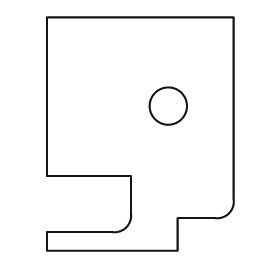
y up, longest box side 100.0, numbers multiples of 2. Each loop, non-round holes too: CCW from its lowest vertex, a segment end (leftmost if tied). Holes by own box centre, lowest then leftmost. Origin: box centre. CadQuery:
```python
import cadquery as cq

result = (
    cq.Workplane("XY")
    .moveTo(-40.0, -50.0)
    .lineTo(16.0, -50.0)
    .lineTo(16.0, -36.0)
    .lineTo(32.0, -36.0)
    .threePointArc((38.0, -34.0), (40.0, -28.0))
    .lineTo(40.0, 50.0)
    .lineTo(-40.0, 50.0)
    .lineTo(-40.0, -18.0)
    .lineTo(-4.0, -18.0)
    .lineTo(-4.0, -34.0)
    .threePointArc((-6.0, -40.0), (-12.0, -42.0))
    .lineTo(-40.0, -42.0)
    .close()
    .moveTo(12.0, 12.0)
    .circle(8.0)
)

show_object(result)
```